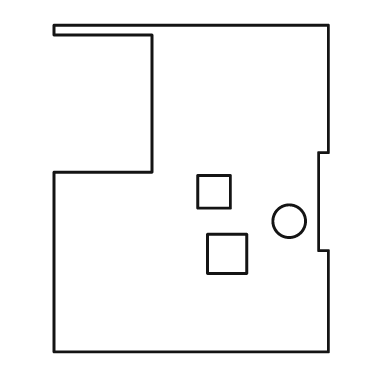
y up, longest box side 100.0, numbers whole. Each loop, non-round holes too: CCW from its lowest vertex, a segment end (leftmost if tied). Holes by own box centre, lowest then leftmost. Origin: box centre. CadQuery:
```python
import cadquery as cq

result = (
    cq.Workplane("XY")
    .moveTo(-42.0, -50.0)
    .lineTo(42.0, -50.0)
    .lineTo(42.0, -19.0)
    .lineTo(39.0, -19.0)
    .lineTo(39.0, 11.0)
    .lineTo(42.0, 11.0)
    .lineTo(42.0, 50.0)
    .lineTo(-42.0, 50.0)
    .lineTo(-42.0, 47.0)
    .lineTo(-12.0, 47.0)
    .lineTo(-12.0, 5.0)
    .lineTo(-42.0, 5.0)
    .close()
    .moveTo(5.0, -26.0)
    .lineTo(17.0, -26.0)
    .lineTo(17.0, -14.0)
    .lineTo(5.0, -14.0)
    .close()
    .moveTo(30.0, -10.0)
    .circle(5.0)
    .moveTo(2.0, -6.0)
    .lineTo(12.0, -6.0)
    .lineTo(12.0, 4.0)
    .lineTo(2.0, 4.0)
    .close()
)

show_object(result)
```